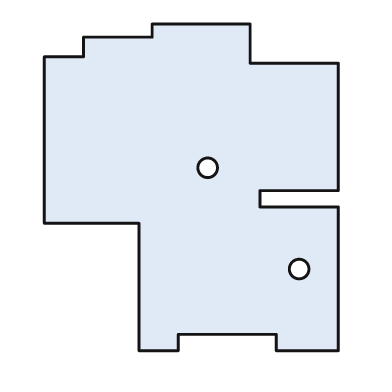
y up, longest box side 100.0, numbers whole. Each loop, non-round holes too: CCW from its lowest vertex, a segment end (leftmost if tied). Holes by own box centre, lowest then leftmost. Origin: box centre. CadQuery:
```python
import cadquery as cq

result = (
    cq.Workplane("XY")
    .moveTo(-16.0, -50.0)
    .lineTo(-4.0, -50.0)
    .lineTo(-4.0, -45.0)
    .lineTo(26.0, -45.0)
    .lineTo(26.0, -50.0)
    .lineTo(45.0, -50.0)
    .lineTo(45.0, -6.0)
    .lineTo(21.0, -6.0)
    .lineTo(21.0, -1.0)
    .lineTo(45.0, -1.0)
    .lineTo(45.0, 38.0)
    .lineTo(18.0, 38.0)
    .lineTo(18.0, 50.0)
    .lineTo(-12.0, 50.0)
    .lineTo(-12.0, 46.0)
    .lineTo(-33.0, 46.0)
    .lineTo(-33.0, 40.0)
    .lineTo(-45.0, 40.0)
    .lineTo(-45.0, -11.0)
    .lineTo(-16.0, -11.0)
    .close()
    .moveTo(33.0, -25.0)
    .circle(3.0)
    .moveTo(5.0, 6.0)
    .circle(3.0)
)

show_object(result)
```